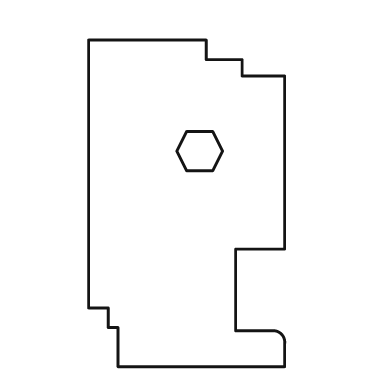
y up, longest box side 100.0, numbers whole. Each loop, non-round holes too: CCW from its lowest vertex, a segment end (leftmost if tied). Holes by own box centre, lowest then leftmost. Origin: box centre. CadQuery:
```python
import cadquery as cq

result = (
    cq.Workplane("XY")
    .moveTo(-21.0, -50.0)
    .lineTo(30.0, -50.0)
    .lineTo(30.0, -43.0)
    .threePointArc((29.0, -40.0), (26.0, -39.0))
    .lineTo(15.0, -39.0)
    .lineTo(15.0, -14.0)
    .lineTo(30.0, -14.0)
    .lineTo(30.0, 39.0)
    .lineTo(17.0, 39.0)
    .lineTo(17.0, 44.0)
    .lineTo(6.0, 44.0)
    .lineTo(6.0, 50.0)
    .lineTo(-30.0, 50.0)
    .lineTo(-30.0, -32.0)
    .lineTo(-24.0, -32.0)
    .lineTo(-24.0, -38.0)
    .lineTo(-21.0, -38.0)
    .close()
    .moveTo(0.0, 10.0)
    .lineTo(8.0, 10.0)
    .lineTo(11.0, 16.0)
    .lineTo(8.0, 22.0)
    .lineTo(0.0, 22.0)
    .lineTo(-3.0, 16.0)
    .close()
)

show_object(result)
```